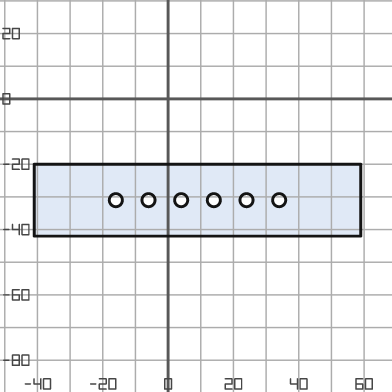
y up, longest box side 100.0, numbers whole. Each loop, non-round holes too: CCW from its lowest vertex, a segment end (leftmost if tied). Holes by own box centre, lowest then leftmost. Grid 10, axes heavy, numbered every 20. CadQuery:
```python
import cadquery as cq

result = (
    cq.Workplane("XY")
    .moveTo(-41.0, -42.0)
    .lineTo(59.0, -42.0)
    .lineTo(59.0, -20.0)
    .lineTo(-41.0, -20.0)
    .close()
    .moveTo(-16.0, -31.0)
    .circle(2.0)
    .moveTo(-6.0, -31.0)
    .circle(2.0)
    .moveTo(4.0, -31.0)
    .circle(2.0)
    .moveTo(14.0, -31.0)
    .circle(2.0)
    .moveTo(24.0, -31.0)
    .circle(2.0)
    .moveTo(34.0, -31.0)
    .circle(2.0)
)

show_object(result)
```